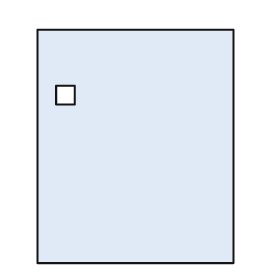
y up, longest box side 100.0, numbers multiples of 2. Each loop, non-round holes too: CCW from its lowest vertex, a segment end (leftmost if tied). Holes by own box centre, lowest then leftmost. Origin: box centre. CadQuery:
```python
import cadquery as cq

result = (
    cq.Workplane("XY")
    .moveTo(-42.0, -50.0)
    .lineTo(42.0, -50.0)
    .lineTo(42.0, 50.0)
    .lineTo(-42.0, 50.0)
    .close()
    .moveTo(-34.0, 18.0)
    .lineTo(-26.0, 18.0)
    .lineTo(-26.0, 26.0)
    .lineTo(-34.0, 26.0)
    .close()
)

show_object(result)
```